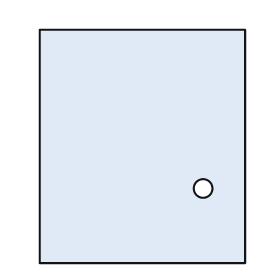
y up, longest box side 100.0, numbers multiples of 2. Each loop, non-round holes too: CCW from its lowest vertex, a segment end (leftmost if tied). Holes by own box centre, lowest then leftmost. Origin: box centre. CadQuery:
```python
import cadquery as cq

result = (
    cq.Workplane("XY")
    .moveTo(-44.0, -50.0)
    .lineTo(44.0, -50.0)
    .lineTo(44.0, 50.0)
    .lineTo(-44.0, 50.0)
    .close()
    .moveTo(26.0, -18.0)
    .circle(4.0)
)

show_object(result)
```